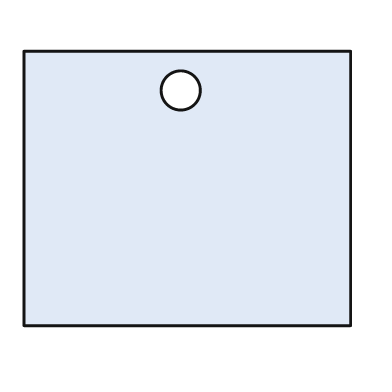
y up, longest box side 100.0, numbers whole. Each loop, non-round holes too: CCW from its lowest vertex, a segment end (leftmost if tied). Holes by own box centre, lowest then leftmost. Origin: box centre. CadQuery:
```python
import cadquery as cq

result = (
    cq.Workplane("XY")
    .moveTo(-50.0, -42.0)
    .lineTo(50.0, -42.0)
    .lineTo(50.0, 42.0)
    .lineTo(-50.0, 42.0)
    .close()
    .moveTo(-2.0, 30.0)
    .circle(6.0)
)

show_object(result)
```